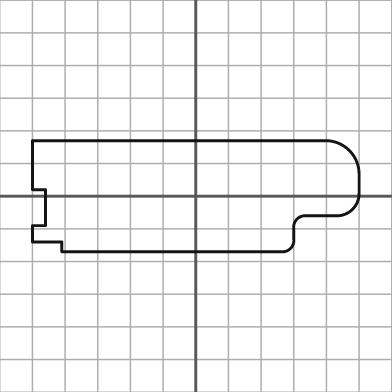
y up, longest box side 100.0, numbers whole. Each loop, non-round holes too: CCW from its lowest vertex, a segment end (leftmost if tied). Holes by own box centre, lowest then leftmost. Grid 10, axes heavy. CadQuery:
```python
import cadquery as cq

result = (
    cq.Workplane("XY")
    .moveTo(-41.0, -17.0)
    .lineTo(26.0, -17.0)
    .threePointArc((29.0, -16.0), (30.0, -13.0))
    .lineTo(30.0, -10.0)
    .threePointArc((31.0, -7.0), (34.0, -6.0))
    .lineTo(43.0, -6.0)
    .threePointArc((48.0, -4.0), (50.0, 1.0))
    .lineTo(50.0, 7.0)
    .threePointArc((47.0, 14.0), (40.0, 17.0))
    .lineTo(-50.0, 17.0)
    .lineTo(-50.0, 2.0)
    .lineTo(-46.0, 2.0)
    .lineTo(-46.0, -9.0)
    .lineTo(-50.0, -9.0)
    .lineTo(-50.0, -14.0)
    .lineTo(-41.0, -14.0)
    .close()
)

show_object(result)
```